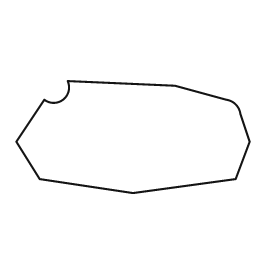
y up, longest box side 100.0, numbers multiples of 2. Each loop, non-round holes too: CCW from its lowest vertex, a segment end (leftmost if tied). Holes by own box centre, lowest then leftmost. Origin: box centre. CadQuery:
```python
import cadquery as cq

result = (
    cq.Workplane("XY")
    .moveTo(0.0, -24.0)
    .lineTo(44.0, -18.0)
    .lineTo(50.0, -2.0)
    .lineTo(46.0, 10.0)
    .threePointArc((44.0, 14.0), (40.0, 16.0))
    .lineTo(18.0, 22.0)
    .lineTo(-28.0, 24.0)
    .threePointArc((-30.0, 16.0), (-38.0, 16.0))
    .lineTo(-50.0, -2.0)
    .lineTo(-40.0, -18.0)
    .close()
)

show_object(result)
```